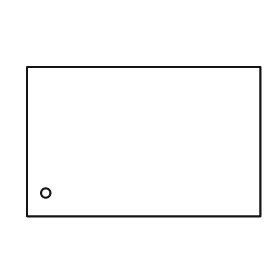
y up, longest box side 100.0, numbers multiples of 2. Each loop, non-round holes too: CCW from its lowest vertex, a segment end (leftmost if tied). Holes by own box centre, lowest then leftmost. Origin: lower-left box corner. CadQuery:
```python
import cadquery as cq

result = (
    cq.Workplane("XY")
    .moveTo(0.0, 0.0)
    .lineTo(100.0, 0.0)
    .lineTo(100.0, 64.0)
    .lineTo(0.0, 64.0)
    .close()
    .moveTo(8.0, 10.0)
    .circle(2.0)
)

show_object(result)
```